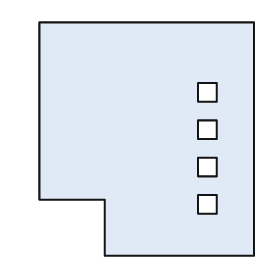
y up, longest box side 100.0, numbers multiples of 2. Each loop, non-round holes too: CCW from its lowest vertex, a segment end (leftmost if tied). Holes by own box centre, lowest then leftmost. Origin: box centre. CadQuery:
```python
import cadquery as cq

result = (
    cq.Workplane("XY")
    .moveTo(-18.0, -50.0)
    .lineTo(46.0, -50.0)
    .lineTo(46.0, 50.0)
    .lineTo(-46.0, 50.0)
    .lineTo(-46.0, -26.0)
    .lineTo(-18.0, -26.0)
    .close()
    .moveTo(22.0, -32.0)
    .lineTo(30.0, -32.0)
    .lineTo(30.0, -24.0)
    .lineTo(22.0, -24.0)
    .close()
    .moveTo(22.0, -16.0)
    .lineTo(30.0, -16.0)
    .lineTo(30.0, -8.0)
    .lineTo(22.0, -8.0)
    .close()
    .moveTo(22.0, 0.0)
    .lineTo(30.0, 0.0)
    .lineTo(30.0, 8.0)
    .lineTo(22.0, 8.0)
    .close()
    .moveTo(22.0, 16.0)
    .lineTo(30.0, 16.0)
    .lineTo(30.0, 24.0)
    .lineTo(22.0, 24.0)
    .close()
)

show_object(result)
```